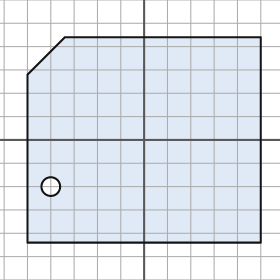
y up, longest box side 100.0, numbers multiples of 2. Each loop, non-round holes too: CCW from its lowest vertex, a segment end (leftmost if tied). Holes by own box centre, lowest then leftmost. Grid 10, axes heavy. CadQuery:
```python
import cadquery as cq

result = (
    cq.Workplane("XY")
    .moveTo(-50.0, -44.0)
    .lineTo(50.0, -44.0)
    .lineTo(50.0, 44.0)
    .lineTo(-34.0, 44.0)
    .lineTo(-50.0, 28.0)
    .close()
    .moveTo(-40.0, -20.0)
    .circle(4.0)
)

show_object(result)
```